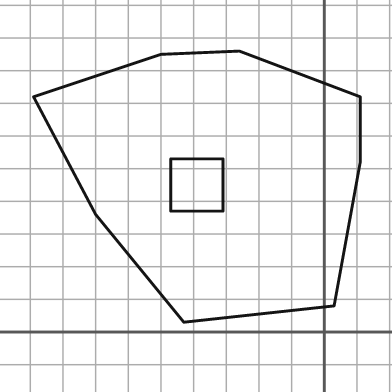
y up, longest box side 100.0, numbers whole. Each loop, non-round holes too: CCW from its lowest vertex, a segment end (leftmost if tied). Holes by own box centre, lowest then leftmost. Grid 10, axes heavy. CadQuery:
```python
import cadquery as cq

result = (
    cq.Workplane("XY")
    .moveTo(-43.0, 3.0)
    .lineTo(3.0, 8.0)
    .lineTo(11.0, 52.0)
    .lineTo(11.0, 72.0)
    .lineTo(-26.0, 86.0)
    .lineTo(-50.0, 85.0)
    .lineTo(-89.0, 72.0)
    .lineTo(-70.0, 36.0)
    .close()
    .moveTo(-47.0, 37.0)
    .lineTo(-31.0, 37.0)
    .lineTo(-31.0, 53.0)
    .lineTo(-47.0, 53.0)
    .close()
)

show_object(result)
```